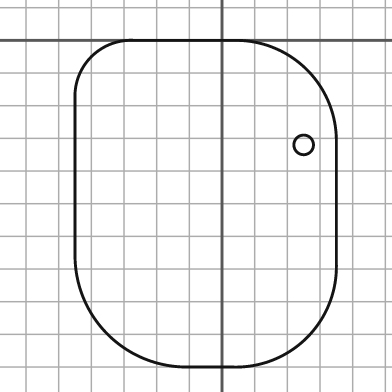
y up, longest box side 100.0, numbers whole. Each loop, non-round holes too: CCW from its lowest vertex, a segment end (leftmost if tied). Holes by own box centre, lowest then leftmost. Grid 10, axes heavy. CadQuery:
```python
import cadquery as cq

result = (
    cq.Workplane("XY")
    .moveTo(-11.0, -100.0)
    .lineTo(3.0, -100.0)
    .threePointArc((26.0, -91.0), (35.0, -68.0))
    .lineTo(35.0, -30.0)
    .threePointArc((26.0, -9.0), (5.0, 0.0))
    .lineTo(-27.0, 0.0)
    .threePointArc((-40.0, -5.0), (-45.0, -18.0))
    .lineTo(-45.0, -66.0)
    .threePointArc((-35.0, -90.0), (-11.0, -100.0))
    .close()
    .moveTo(25.0, -32.0)
    .circle(3.0)
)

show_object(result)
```